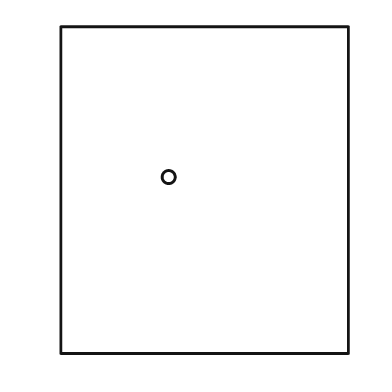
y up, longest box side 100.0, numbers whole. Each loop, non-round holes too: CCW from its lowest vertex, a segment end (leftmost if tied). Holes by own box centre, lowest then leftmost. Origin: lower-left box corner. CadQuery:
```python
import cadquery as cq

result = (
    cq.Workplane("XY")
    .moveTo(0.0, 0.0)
    .lineTo(88.0, 0.0)
    .lineTo(88.0, 100.0)
    .lineTo(0.0, 100.0)
    .close()
    .moveTo(33.0, 54.0)
    .circle(2.0)
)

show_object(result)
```